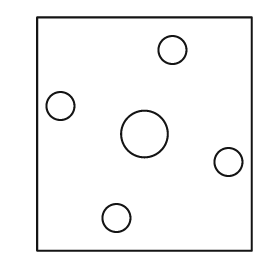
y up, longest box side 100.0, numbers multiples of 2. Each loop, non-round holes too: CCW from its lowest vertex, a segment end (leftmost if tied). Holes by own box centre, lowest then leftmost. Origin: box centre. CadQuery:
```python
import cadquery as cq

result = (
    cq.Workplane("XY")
    .moveTo(-46.0, -50.0)
    .lineTo(46.0, -50.0)
    .lineTo(46.0, 50.0)
    .lineTo(-46.0, 50.0)
    .close()
    .moveTo(-12.0, -36.0)
    .circle(6.0)
    .moveTo(36.0, -12.0)
    .circle(6.0)
    .moveTo(0.0, 0.0)
    .circle(10.0)
    .moveTo(-36.0, 12.0)
    .circle(6.0)
    .moveTo(12.0, 36.0)
    .circle(6.0)
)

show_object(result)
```